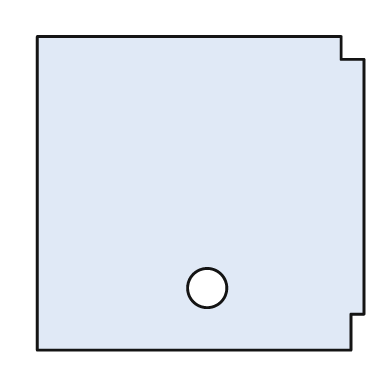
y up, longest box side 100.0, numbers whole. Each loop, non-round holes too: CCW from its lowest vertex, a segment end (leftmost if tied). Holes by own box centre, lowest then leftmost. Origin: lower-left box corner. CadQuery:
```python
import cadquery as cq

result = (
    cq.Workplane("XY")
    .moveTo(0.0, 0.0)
    .lineTo(96.0, 0.0)
    .lineTo(96.0, 11.0)
    .lineTo(100.0, 11.0)
    .lineTo(100.0, 89.0)
    .lineTo(93.0, 89.0)
    .lineTo(93.0, 96.0)
    .lineTo(0.0, 96.0)
    .close()
    .moveTo(52.0, 19.0)
    .circle(6.0)
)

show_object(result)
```